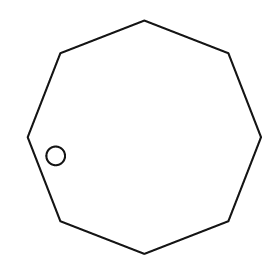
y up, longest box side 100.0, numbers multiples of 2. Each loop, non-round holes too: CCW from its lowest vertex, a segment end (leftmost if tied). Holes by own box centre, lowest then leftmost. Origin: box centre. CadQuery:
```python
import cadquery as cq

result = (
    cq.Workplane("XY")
    .moveTo(0.0, -50.0)
    .lineTo(36.0, -36.0)
    .lineTo(50.0, 0.0)
    .lineTo(36.0, 36.0)
    .lineTo(0.0, 50.0)
    .lineTo(-36.0, 36.0)
    .lineTo(-50.0, 0.0)
    .lineTo(-36.0, -36.0)
    .close()
    .moveTo(-38.0, -8.0)
    .circle(4.0)
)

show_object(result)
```